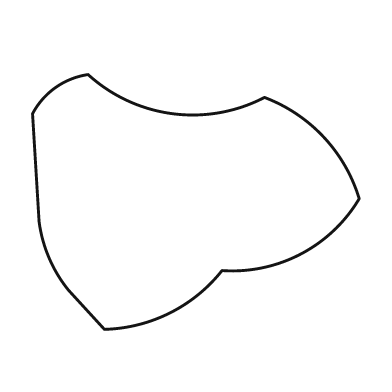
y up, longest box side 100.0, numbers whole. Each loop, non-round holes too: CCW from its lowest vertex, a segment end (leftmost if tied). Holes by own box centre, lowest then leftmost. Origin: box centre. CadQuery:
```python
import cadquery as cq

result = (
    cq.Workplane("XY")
    .moveTo(-28.0, -39.0)
    .threePointArc((-8.0, -34.0), (8.0, -21.0))
    .threePointArc((32.0, -16.0), (50.0, 1.0))
    .threePointArc((39.0, 20.0), (21.0, 32.0))
    .threePointArc((-7.0, 27.0), (-33.0, 39.0))
    .threePointArc((-43.0, 35.0), (-50.0, 27.0))
    .lineTo(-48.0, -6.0)
    .threePointArc((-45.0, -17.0), (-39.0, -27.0))
    .close()
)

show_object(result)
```